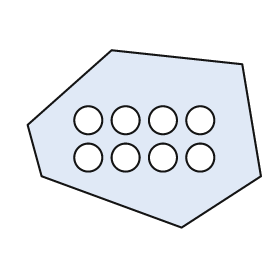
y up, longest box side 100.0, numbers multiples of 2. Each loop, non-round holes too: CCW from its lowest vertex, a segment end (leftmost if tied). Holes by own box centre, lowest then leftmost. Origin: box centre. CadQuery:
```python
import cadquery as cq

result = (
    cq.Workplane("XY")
    .moveTo(16.0, -38.0)
    .lineTo(50.0, -16.0)
    .lineTo(42.0, 32.0)
    .lineTo(-14.0, 38.0)
    .lineTo(-50.0, 6.0)
    .lineTo(-44.0, -16.0)
    .close()
    .moveTo(-24.0, -8.0)
    .circle(6.0)
    .moveTo(-8.0, -8.0)
    .circle(6.0)
    .moveTo(8.0, -8.0)
    .circle(6.0)
    .moveTo(24.0, -8.0)
    .circle(6.0)
    .moveTo(-24.0, 8.0)
    .circle(6.0)
    .moveTo(-8.0, 8.0)
    .circle(6.0)
    .moveTo(8.0, 8.0)
    .circle(6.0)
    .moveTo(24.0, 8.0)
    .circle(6.0)
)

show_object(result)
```